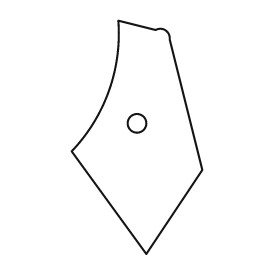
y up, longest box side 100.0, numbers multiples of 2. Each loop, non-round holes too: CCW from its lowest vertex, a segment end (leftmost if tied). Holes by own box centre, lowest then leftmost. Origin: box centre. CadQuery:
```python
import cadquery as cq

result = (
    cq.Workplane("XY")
    .moveTo(4.0, -50.0)
    .lineTo(28.0, -14.0)
    .lineTo(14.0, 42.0)
    .threePointArc((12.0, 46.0), (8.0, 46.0))
    .lineTo(-8.0, 50.0)
    .threePointArc((-12.0, 20.0), (-28.0, -6.0))
    .close()
    .moveTo(0.0, 6.0)
    .circle(4.0)
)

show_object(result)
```